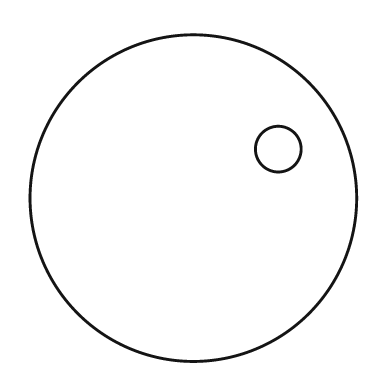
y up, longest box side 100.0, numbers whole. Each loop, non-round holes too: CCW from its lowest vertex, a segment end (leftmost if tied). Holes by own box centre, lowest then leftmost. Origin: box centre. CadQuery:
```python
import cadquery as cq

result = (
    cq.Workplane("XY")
    .moveTo(0.0, 0.0)
    .circle(50.0)
    .moveTo(26.0, 15.0)
    .circle(7.0)
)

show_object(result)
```